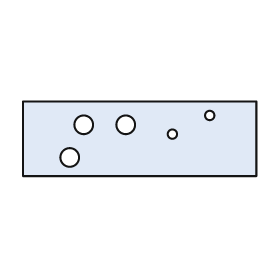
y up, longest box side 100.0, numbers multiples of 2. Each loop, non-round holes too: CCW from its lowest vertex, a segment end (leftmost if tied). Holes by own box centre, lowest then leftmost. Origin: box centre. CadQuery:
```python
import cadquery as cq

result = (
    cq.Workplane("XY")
    .moveTo(-50.0, -16.0)
    .lineTo(50.0, -16.0)
    .lineTo(50.0, 16.0)
    .lineTo(-50.0, 16.0)
    .close()
    .moveTo(-30.0, -8.0)
    .circle(4.0)
    .moveTo(14.0, 2.0)
    .circle(2.0)
    .moveTo(-24.0, 6.0)
    .circle(4.0)
    .moveTo(-6.0, 6.0)
    .circle(4.0)
    .moveTo(30.0, 10.0)
    .circle(2.0)
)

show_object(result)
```